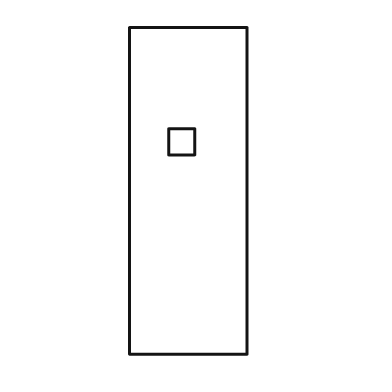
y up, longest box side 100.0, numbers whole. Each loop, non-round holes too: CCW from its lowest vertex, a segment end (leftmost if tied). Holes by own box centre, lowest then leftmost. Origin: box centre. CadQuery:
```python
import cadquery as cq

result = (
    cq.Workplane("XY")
    .moveTo(-18.0, -50.0)
    .lineTo(18.0, -50.0)
    .lineTo(18.0, 50.0)
    .lineTo(-18.0, 50.0)
    .close()
    .moveTo(-6.0, 11.0)
    .lineTo(2.0, 11.0)
    .lineTo(2.0, 19.0)
    .lineTo(-6.0, 19.0)
    .close()
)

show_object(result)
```